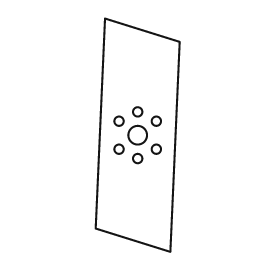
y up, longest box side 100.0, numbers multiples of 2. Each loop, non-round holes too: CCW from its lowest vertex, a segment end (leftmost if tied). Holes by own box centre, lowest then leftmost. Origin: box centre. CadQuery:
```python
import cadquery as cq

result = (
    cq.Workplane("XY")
    .moveTo(14.0, -50.0)
    .lineTo(18.0, 40.0)
    .lineTo(-14.0, 50.0)
    .lineTo(-18.0, -40.0)
    .close()
    .moveTo(0.0, -10.0)
    .circle(2.0)
    .moveTo(-8.0, -6.0)
    .circle(2.0)
    .moveTo(8.0, -6.0)
    .circle(2.0)
    .moveTo(0.0, 0.0)
    .circle(4.0)
    .moveTo(-8.0, 6.0)
    .circle(2.0)
    .moveTo(8.0, 6.0)
    .circle(2.0)
    .moveTo(0.0, 10.0)
    .circle(2.0)
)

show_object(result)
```